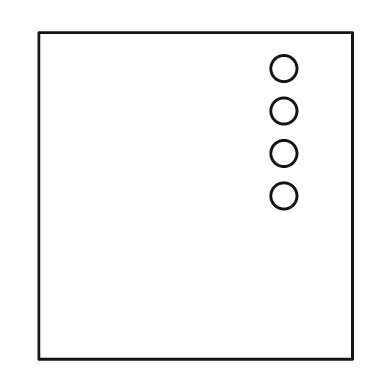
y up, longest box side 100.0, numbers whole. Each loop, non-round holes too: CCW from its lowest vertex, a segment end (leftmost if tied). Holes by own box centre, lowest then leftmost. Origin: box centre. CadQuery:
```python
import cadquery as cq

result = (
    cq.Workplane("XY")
    .moveTo(-48.0, -50.0)
    .lineTo(48.0, -50.0)
    .lineTo(48.0, 50.0)
    .lineTo(-48.0, 50.0)
    .close()
    .moveTo(27.0, 0.0)
    .circle(4.0)
    .moveTo(27.0, 13.0)
    .circle(4.0)
    .moveTo(27.0, 26.0)
    .circle(4.0)
    .moveTo(27.0, 39.0)
    .circle(4.0)
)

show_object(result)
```